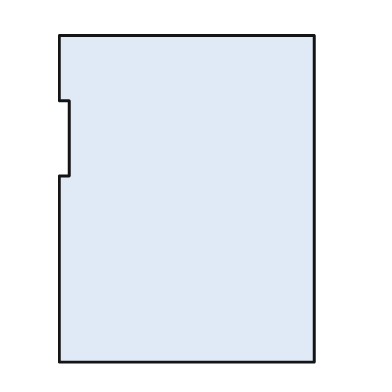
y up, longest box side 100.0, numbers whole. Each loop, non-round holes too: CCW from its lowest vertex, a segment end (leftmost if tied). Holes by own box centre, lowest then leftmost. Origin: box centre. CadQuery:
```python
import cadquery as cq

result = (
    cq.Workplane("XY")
    .moveTo(-39.0, -50.0)
    .lineTo(39.0, -50.0)
    .lineTo(39.0, 50.0)
    .lineTo(-39.0, 50.0)
    .lineTo(-39.0, 30.0)
    .lineTo(-36.0, 30.0)
    .lineTo(-36.0, 7.0)
    .lineTo(-39.0, 7.0)
    .close()
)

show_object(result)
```